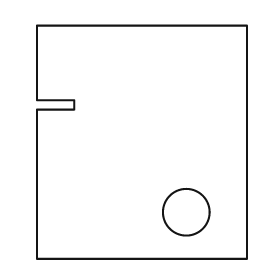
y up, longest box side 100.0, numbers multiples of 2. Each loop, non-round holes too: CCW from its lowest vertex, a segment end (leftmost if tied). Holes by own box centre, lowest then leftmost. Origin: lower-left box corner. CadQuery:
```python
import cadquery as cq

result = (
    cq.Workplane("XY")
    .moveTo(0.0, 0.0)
    .lineTo(90.0, 0.0)
    .lineTo(90.0, 100.0)
    .lineTo(0.0, 100.0)
    .lineTo(0.0, 68.0)
    .lineTo(16.0, 68.0)
    .lineTo(16.0, 64.0)
    .lineTo(0.0, 64.0)
    .close()
    .moveTo(64.0, 20.0)
    .circle(10.0)
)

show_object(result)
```